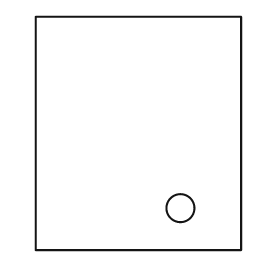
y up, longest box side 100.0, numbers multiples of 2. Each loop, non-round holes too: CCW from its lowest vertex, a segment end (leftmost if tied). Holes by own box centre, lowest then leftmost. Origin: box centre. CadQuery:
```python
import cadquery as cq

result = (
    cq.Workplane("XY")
    .moveTo(-44.0, -50.0)
    .lineTo(44.0, -50.0)
    .lineTo(44.0, 50.0)
    .lineTo(-44.0, 50.0)
    .close()
    .moveTo(18.0, -32.0)
    .circle(6.0)
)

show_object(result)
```